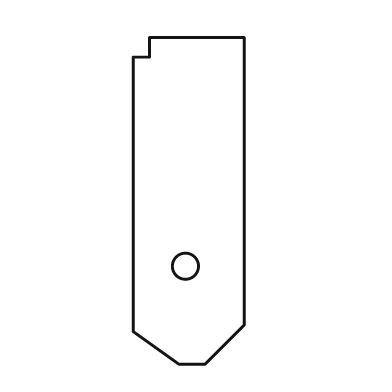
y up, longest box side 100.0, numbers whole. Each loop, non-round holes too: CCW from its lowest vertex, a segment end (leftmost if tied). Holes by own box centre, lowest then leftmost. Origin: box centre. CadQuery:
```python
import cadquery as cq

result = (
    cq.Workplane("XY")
    .moveTo(-3.0, -50.0)
    .lineTo(5.0, -50.0)
    .lineTo(17.0, -38.0)
    .lineTo(17.0, 50.0)
    .lineTo(-12.0, 50.0)
    .lineTo(-12.0, 44.0)
    .lineTo(-17.0, 44.0)
    .lineTo(-17.0, -40.0)
    .close()
    .moveTo(-1.0, -20.0)
    .circle(4.0)
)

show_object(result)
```